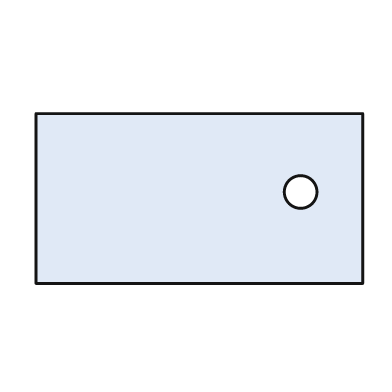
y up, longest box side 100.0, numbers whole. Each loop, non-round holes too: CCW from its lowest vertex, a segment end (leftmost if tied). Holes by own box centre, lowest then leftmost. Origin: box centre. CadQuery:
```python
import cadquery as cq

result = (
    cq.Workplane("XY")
    .moveTo(-50.0, -26.0)
    .lineTo(50.0, -26.0)
    .lineTo(50.0, 26.0)
    .lineTo(-50.0, 26.0)
    .close()
    .moveTo(31.0, 2.0)
    .circle(5.0)
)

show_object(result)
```